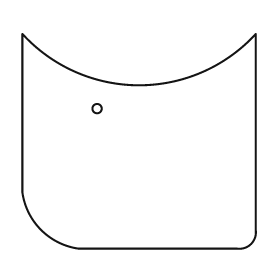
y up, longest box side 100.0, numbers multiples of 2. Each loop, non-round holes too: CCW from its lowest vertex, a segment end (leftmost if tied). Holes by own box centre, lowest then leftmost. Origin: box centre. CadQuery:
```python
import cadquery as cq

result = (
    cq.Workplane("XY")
    .moveTo(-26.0, -46.0)
    .lineTo(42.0, -46.0)
    .threePointArc((48.0, -44.0), (50.0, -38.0))
    .lineTo(50.0, 46.0)
    .threePointArc((0.0, 24.0), (-50.0, 46.0))
    .lineTo(-50.0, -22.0)
    .threePointArc((-42.0, -38.0), (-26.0, -46.0))
    .close()
    .moveTo(-18.0, 14.0)
    .circle(2.0)
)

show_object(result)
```